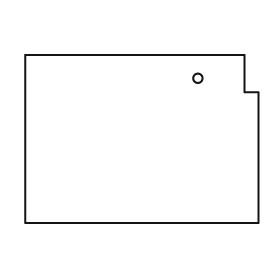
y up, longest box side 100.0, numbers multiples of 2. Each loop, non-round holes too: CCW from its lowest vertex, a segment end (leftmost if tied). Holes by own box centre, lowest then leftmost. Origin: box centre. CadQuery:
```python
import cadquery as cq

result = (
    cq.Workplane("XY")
    .moveTo(-50.0, -36.0)
    .lineTo(50.0, -36.0)
    .lineTo(50.0, 20.0)
    .lineTo(44.0, 20.0)
    .lineTo(44.0, 36.0)
    .lineTo(-50.0, 36.0)
    .close()
    .moveTo(24.0, 26.0)
    .circle(2.0)
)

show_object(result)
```